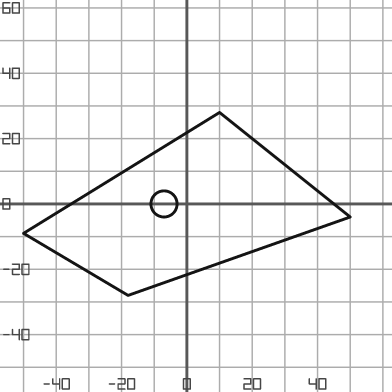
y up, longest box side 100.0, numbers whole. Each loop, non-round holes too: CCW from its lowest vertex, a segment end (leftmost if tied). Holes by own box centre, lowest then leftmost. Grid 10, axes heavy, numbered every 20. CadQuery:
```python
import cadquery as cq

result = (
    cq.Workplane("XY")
    .moveTo(-18.0, -28.0)
    .lineTo(50.0, -4.0)
    .lineTo(10.0, 28.0)
    .lineTo(-50.0, -9.0)
    .close()
    .moveTo(-7.0, 0.0)
    .circle(4.0)
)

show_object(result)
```